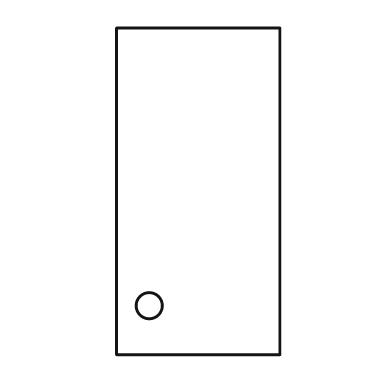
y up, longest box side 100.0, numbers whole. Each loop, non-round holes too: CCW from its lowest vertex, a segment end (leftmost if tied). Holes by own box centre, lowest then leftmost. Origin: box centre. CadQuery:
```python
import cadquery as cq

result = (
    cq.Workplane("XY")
    .moveTo(-25.0, -50.0)
    .lineTo(25.0, -50.0)
    .lineTo(25.0, 50.0)
    .lineTo(-25.0, 50.0)
    .close()
    .moveTo(-15.0, -35.0)
    .circle(4.0)
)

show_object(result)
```